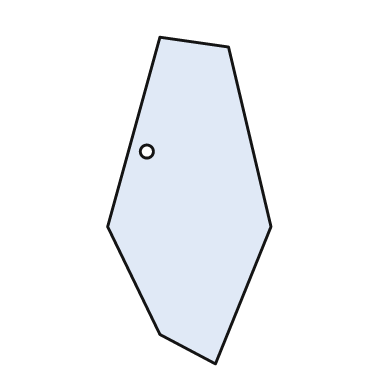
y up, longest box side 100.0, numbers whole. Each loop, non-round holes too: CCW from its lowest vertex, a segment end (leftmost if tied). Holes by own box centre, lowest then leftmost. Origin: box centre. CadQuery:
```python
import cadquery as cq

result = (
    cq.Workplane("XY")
    .moveTo(8.0, -50.0)
    .lineTo(25.0, -8.0)
    .lineTo(12.0, 47.0)
    .lineTo(-9.0, 50.0)
    .lineTo(-25.0, -8.0)
    .lineTo(-9.0, -41.0)
    .close()
    .moveTo(-13.0, 15.0)
    .circle(2.0)
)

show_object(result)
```